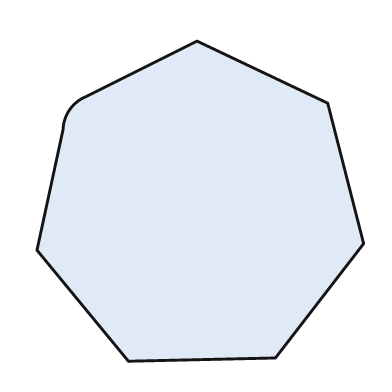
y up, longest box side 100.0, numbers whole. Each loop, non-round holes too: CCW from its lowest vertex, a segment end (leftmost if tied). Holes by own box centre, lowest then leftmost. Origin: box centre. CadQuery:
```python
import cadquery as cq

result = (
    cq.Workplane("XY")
    .moveTo(-22.0, -49.0)
    .lineTo(23.0, -48.0)
    .lineTo(50.0, -13.0)
    .lineTo(39.0, 30.0)
    .lineTo(-1.0, 49.0)
    .lineTo(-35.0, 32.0)
    .threePointArc((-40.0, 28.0), (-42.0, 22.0))
    .lineTo(-50.0, -15.0)
    .close()
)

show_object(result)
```